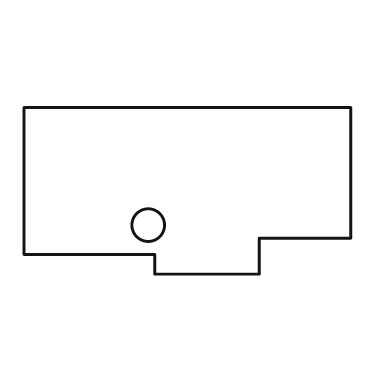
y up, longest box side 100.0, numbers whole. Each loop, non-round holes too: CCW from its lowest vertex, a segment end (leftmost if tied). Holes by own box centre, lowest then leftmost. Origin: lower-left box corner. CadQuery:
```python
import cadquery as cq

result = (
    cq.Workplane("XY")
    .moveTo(40.0, 0.0)
    .lineTo(72.0, 0.0)
    .lineTo(72.0, 11.0)
    .lineTo(100.0, 11.0)
    .lineTo(100.0, 51.0)
    .lineTo(0.0, 51.0)
    .lineTo(0.0, 6.0)
    .lineTo(40.0, 6.0)
    .close()
    .moveTo(38.0, 15.0)
    .circle(5.0)
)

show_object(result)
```